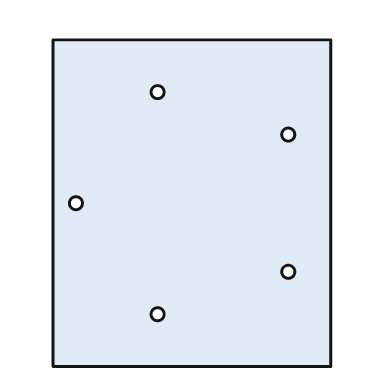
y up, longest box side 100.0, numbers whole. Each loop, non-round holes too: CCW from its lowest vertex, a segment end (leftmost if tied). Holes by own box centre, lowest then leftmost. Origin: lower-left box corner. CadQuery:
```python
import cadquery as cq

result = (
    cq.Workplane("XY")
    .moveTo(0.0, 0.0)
    .lineTo(85.0, 0.0)
    .lineTo(85.0, 100.0)
    .lineTo(0.0, 100.0)
    .close()
    .moveTo(32.0, 16.0)
    .circle(2.0)
    .moveTo(72.0, 29.0)
    .circle(2.0)
    .moveTo(7.0, 50.0)
    .circle(2.0)
    .moveTo(72.0, 71.0)
    .circle(2.0)
    .moveTo(32.0, 84.0)
    .circle(2.0)
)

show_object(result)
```